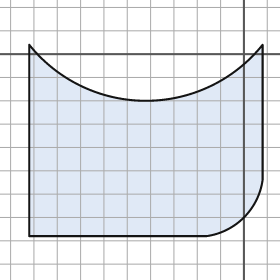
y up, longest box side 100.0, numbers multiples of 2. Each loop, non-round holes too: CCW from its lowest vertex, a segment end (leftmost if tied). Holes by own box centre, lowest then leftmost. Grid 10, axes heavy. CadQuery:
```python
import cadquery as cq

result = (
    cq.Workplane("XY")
    .moveTo(-92.0, -78.0)
    .lineTo(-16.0, -78.0)
    .threePointArc((0.0, -70.0), (8.0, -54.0))
    .lineTo(8.0, 4.0)
    .threePointArc((-42.0, -20.0), (-92.0, 4.0))
    .close()
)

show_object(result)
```